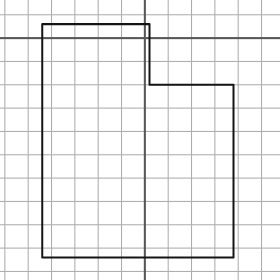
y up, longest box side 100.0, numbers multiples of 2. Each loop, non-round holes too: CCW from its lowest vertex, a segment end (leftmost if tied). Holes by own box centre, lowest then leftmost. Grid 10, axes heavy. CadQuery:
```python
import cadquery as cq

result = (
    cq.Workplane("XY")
    .moveTo(-44.0, -94.0)
    .lineTo(38.0, -94.0)
    .lineTo(38.0, -20.0)
    .lineTo(2.0, -20.0)
    .lineTo(2.0, 6.0)
    .lineTo(-44.0, 6.0)
    .close()
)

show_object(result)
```